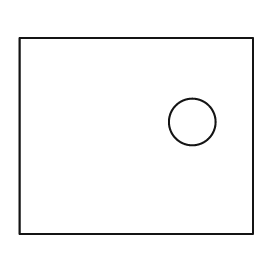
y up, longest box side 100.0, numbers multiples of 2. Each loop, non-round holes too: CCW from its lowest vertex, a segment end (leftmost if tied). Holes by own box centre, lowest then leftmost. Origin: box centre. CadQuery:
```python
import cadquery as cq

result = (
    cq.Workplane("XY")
    .moveTo(-50.0, -42.0)
    .lineTo(50.0, -42.0)
    .lineTo(50.0, 42.0)
    .lineTo(-50.0, 42.0)
    .close()
    .moveTo(24.0, 6.0)
    .circle(10.0)
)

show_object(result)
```